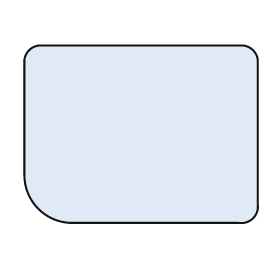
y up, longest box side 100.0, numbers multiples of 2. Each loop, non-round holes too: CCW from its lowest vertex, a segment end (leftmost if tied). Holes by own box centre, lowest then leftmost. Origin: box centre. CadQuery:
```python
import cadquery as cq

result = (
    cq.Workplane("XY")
    .moveTo(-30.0, -38.0)
    .lineTo(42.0, -38.0)
    .threePointArc((48.0, -36.0), (50.0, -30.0))
    .lineTo(50.0, 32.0)
    .threePointArc((48.0, 36.0), (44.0, 38.0))
    .lineTo(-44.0, 38.0)
    .threePointArc((-48.0, 36.0), (-50.0, 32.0))
    .lineTo(-50.0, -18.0)
    .threePointArc((-44.0, -32.0), (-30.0, -38.0))
    .close()
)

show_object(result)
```